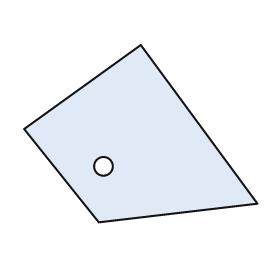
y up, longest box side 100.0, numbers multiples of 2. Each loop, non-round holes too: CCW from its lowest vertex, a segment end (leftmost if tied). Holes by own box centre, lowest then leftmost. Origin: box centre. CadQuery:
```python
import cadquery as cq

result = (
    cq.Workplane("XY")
    .moveTo(-18.0, -38.0)
    .lineTo(50.0, -30.0)
    .lineTo(0.0, 38.0)
    .lineTo(-50.0, 2.0)
    .close()
    .moveTo(-16.0, -14.0)
    .circle(4.0)
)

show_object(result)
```